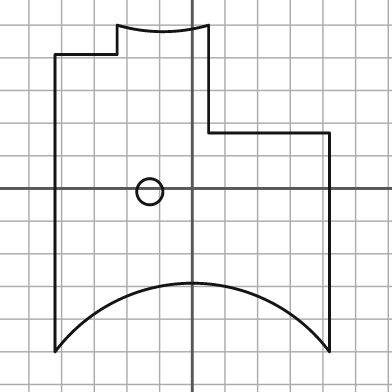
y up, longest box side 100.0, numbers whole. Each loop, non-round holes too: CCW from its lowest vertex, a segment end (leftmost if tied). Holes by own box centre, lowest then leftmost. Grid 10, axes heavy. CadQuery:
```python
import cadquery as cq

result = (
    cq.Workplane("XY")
    .moveTo(-42.0, -50.0)
    .threePointArc((0.0, -29.0), (42.0, -50.0))
    .lineTo(42.0, 17.0)
    .lineTo(5.0, 17.0)
    .lineTo(5.0, 50.0)
    .threePointArc((-9.0, 48.0), (-23.0, 50.0))
    .lineTo(-23.0, 41.0)
    .lineTo(-42.0, 41.0)
    .close()
    .moveTo(-13.0, -1.0)
    .circle(4.0)
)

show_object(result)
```